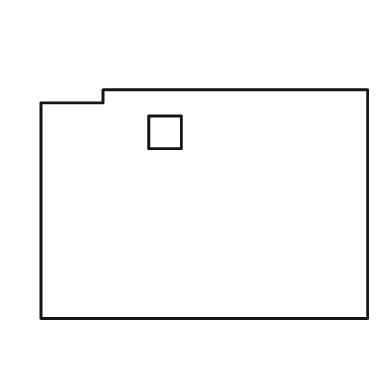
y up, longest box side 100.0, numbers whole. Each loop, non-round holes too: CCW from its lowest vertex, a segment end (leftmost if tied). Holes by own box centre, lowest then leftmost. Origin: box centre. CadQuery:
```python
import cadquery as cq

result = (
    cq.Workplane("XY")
    .moveTo(-50.0, -35.0)
    .lineTo(50.0, -35.0)
    .lineTo(50.0, 35.0)
    .lineTo(-31.0, 35.0)
    .lineTo(-31.0, 31.0)
    .lineTo(-50.0, 31.0)
    .close()
    .moveTo(-17.0, 17.0)
    .lineTo(-7.0, 17.0)
    .lineTo(-7.0, 27.0)
    .lineTo(-17.0, 27.0)
    .close()
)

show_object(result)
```